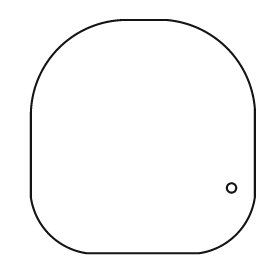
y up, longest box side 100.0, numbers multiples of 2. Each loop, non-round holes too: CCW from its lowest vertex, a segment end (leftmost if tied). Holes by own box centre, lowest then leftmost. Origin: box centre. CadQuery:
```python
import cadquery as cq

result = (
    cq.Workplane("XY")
    .moveTo(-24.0, -50.0)
    .lineTo(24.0, -50.0)
    .threePointArc((40.0, -42.0), (48.0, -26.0))
    .lineTo(48.0, 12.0)
    .threePointArc((36.0, 38.0), (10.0, 50.0))
    .lineTo(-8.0, 50.0)
    .threePointArc((-36.0, 38.0), (-48.0, 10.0))
    .lineTo(-48.0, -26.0)
    .threePointArc((-40.0, -42.0), (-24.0, -50.0))
    .close()
    .moveTo(38.0, -22.0)
    .circle(2.0)
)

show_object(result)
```